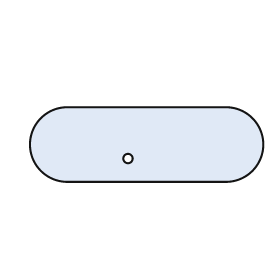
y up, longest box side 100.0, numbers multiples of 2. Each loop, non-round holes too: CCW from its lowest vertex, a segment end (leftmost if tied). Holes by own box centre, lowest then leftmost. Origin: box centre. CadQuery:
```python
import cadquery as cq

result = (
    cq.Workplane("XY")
    .moveTo(-34.0, -16.0)
    .lineTo(34.0, -16.0)
    .threePointArc((50.0, 0.0), (34.0, 16.0))
    .lineTo(-34.0, 16.0)
    .threePointArc((-50.0, 0.0), (-34.0, -16.0))
    .close()
    .moveTo(-8.0, -6.0)
    .circle(2.0)
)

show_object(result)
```